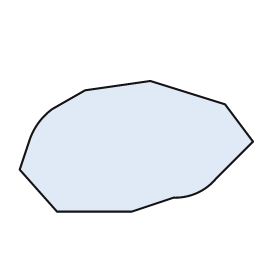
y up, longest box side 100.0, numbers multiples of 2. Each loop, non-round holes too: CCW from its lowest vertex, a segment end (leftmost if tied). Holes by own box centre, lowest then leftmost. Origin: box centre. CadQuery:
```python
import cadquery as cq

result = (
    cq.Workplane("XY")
    .moveTo(-34.0, -28.0)
    .lineTo(-2.0, -28.0)
    .lineTo(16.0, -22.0)
    .threePointArc((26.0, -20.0), (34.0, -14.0))
    .lineTo(50.0, 2.0)
    .lineTo(38.0, 18.0)
    .lineTo(6.0, 28.0)
    .lineTo(-22.0, 24.0)
    .lineTo(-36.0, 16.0)
    .threePointArc((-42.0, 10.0), (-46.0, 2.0))
    .lineTo(-50.0, -10.0)
    .close()
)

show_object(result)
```